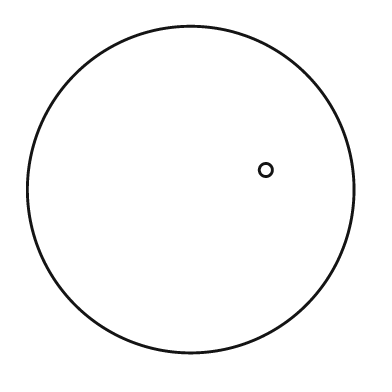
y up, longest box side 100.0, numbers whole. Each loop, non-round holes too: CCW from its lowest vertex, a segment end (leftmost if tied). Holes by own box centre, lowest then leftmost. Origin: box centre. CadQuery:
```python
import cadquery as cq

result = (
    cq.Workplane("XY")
    .moveTo(0.0, 0.0)
    .circle(50.0)
    .moveTo(23.0, 6.0)
    .circle(2.0)
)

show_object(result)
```